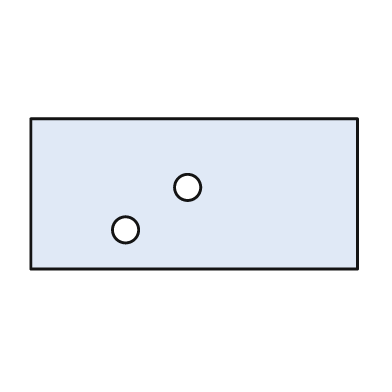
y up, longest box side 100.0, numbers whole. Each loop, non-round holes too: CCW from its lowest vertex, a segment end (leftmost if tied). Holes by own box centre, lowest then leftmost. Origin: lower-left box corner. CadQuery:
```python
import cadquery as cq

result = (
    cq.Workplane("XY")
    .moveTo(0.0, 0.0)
    .lineTo(100.0, 0.0)
    .lineTo(100.0, 46.0)
    .lineTo(0.0, 46.0)
    .close()
    .moveTo(29.0, 12.0)
    .circle(4.0)
    .moveTo(48.0, 25.0)
    .circle(4.0)
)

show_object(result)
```